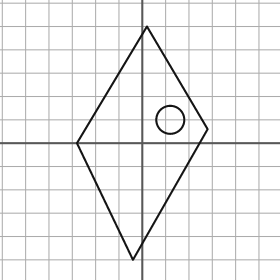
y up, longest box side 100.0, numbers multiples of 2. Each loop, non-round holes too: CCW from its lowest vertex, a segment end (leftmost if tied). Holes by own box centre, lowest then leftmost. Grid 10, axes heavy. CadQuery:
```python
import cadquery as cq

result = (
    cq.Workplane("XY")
    .moveTo(-4.0, -50.0)
    .lineTo(28.0, 6.0)
    .lineTo(2.0, 50.0)
    .lineTo(-28.0, 0.0)
    .close()
    .moveTo(12.0, 10.0)
    .circle(6.0)
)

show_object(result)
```